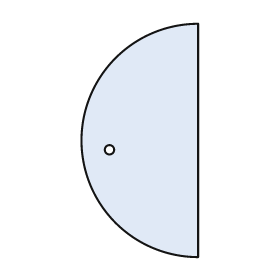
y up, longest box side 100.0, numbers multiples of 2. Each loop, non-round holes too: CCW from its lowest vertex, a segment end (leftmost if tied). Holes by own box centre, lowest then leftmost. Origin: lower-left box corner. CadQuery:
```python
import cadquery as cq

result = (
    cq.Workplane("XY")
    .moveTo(50.0, 0.0)
    .lineTo(50.0, 100.0)
    .threePointArc((0.0, 50.0), (50.0, 0.0))
    .close()
    .moveTo(12.0, 46.0)
    .circle(2.0)
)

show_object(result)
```